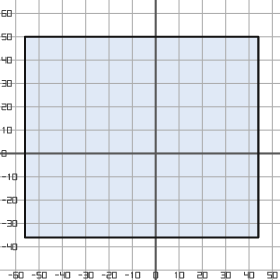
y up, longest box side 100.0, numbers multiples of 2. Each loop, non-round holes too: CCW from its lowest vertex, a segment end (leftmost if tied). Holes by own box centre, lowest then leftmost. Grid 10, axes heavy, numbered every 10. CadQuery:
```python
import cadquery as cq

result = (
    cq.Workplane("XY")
    .moveTo(-56.0, -36.0)
    .lineTo(44.0, -36.0)
    .lineTo(44.0, 50.0)
    .lineTo(-56.0, 50.0)
    .close()
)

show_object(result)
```